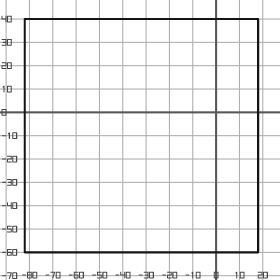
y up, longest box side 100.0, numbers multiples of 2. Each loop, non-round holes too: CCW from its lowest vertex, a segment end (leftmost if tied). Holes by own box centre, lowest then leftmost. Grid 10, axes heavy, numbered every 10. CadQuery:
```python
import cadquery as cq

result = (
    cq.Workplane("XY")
    .moveTo(-82.0, -60.0)
    .lineTo(18.0, -60.0)
    .lineTo(18.0, 40.0)
    .lineTo(-82.0, 40.0)
    .close()
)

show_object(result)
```